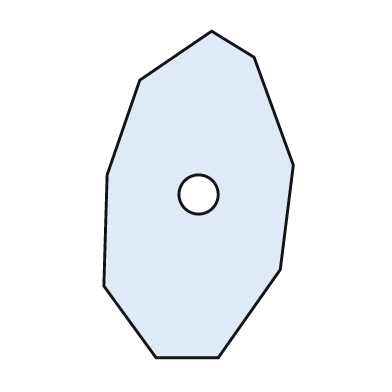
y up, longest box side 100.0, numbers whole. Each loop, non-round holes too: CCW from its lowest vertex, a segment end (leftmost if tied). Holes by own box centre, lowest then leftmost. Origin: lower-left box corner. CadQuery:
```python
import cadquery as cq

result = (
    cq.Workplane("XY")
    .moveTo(16.0, 0.0)
    .lineTo(35.0, 0.0)
    .lineTo(54.0, 27.0)
    .lineTo(58.0, 59.0)
    .lineTo(46.0, 92.0)
    .lineTo(33.0, 100.0)
    .lineTo(11.0, 85.0)
    .lineTo(1.0, 56.0)
    .lineTo(0.0, 22.0)
    .close()
    .moveTo(29.0, 50.0)
    .circle(6.0)
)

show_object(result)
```